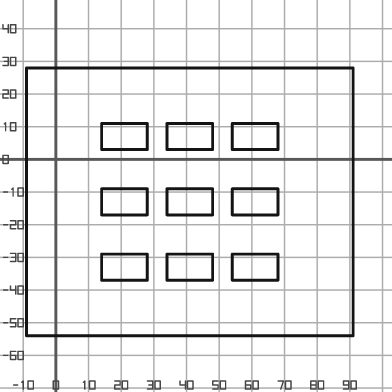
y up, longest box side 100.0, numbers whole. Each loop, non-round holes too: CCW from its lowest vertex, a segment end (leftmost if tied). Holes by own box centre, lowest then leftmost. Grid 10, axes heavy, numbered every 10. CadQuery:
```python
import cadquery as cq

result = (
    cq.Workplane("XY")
    .moveTo(-9.0, -54.0)
    .lineTo(91.0, -54.0)
    .lineTo(91.0, 28.0)
    .lineTo(-9.0, 28.0)
    .close()
    .moveTo(14.0, -37.0)
    .lineTo(28.0, -37.0)
    .lineTo(28.0, -29.0)
    .lineTo(14.0, -29.0)
    .close()
    .moveTo(34.0, -37.0)
    .lineTo(48.0, -37.0)
    .lineTo(48.0, -29.0)
    .lineTo(34.0, -29.0)
    .close()
    .moveTo(54.0, -37.0)
    .lineTo(68.0, -37.0)
    .lineTo(68.0, -29.0)
    .lineTo(54.0, -29.0)
    .close()
    .moveTo(14.0, -17.0)
    .lineTo(28.0, -17.0)
    .lineTo(28.0, -9.0)
    .lineTo(14.0, -9.0)
    .close()
    .moveTo(34.0, -17.0)
    .lineTo(48.0, -17.0)
    .lineTo(48.0, -9.0)
    .lineTo(34.0, -9.0)
    .close()
    .moveTo(54.0, -17.0)
    .lineTo(68.0, -17.0)
    .lineTo(68.0, -9.0)
    .lineTo(54.0, -9.0)
    .close()
    .moveTo(14.0, 3.0)
    .lineTo(28.0, 3.0)
    .lineTo(28.0, 11.0)
    .lineTo(14.0, 11.0)
    .close()
    .moveTo(34.0, 3.0)
    .lineTo(48.0, 3.0)
    .lineTo(48.0, 11.0)
    .lineTo(34.0, 11.0)
    .close()
    .moveTo(54.0, 3.0)
    .lineTo(68.0, 3.0)
    .lineTo(68.0, 11.0)
    .lineTo(54.0, 11.0)
    .close()
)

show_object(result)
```